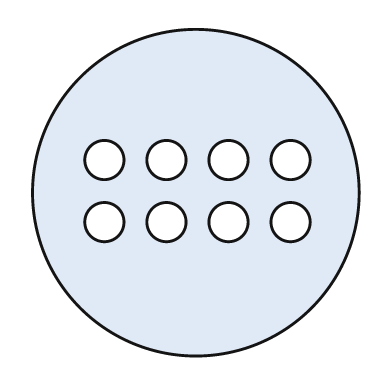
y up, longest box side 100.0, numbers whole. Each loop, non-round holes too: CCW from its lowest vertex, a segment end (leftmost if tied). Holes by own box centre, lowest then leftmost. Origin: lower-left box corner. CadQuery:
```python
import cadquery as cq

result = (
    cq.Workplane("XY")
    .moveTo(50.0, 50.0)
    .circle(50.0)
    .moveTo(22.0, 41.0)
    .circle(6.0)
    .moveTo(41.0, 41.0)
    .circle(6.0)
    .moveTo(60.0, 41.0)
    .circle(6.0)
    .moveTo(79.0, 41.0)
    .circle(6.0)
    .moveTo(22.0, 60.0)
    .circle(6.0)
    .moveTo(41.0, 60.0)
    .circle(6.0)
    .moveTo(60.0, 60.0)
    .circle(6.0)
    .moveTo(79.0, 60.0)
    .circle(6.0)
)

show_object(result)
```